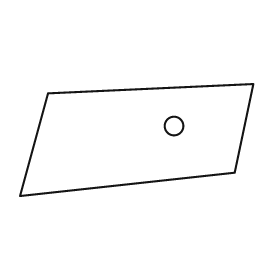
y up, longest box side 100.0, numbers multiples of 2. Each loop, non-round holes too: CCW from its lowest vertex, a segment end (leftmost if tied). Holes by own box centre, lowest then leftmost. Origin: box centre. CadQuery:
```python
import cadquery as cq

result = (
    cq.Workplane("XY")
    .moveTo(-50.0, -24.0)
    .lineTo(42.0, -14.0)
    .lineTo(50.0, 24.0)
    .lineTo(-38.0, 20.0)
    .close()
    .moveTo(16.0, 6.0)
    .circle(4.0)
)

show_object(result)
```